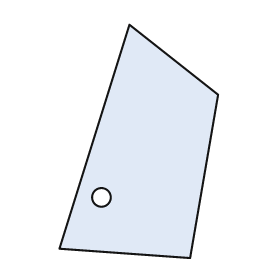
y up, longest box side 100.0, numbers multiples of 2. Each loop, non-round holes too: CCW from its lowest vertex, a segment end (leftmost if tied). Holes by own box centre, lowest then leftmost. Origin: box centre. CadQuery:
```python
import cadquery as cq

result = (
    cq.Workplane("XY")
    .moveTo(22.0, -50.0)
    .lineTo(34.0, 20.0)
    .lineTo(-4.0, 50.0)
    .lineTo(-34.0, -46.0)
    .close()
    .moveTo(-16.0, -24.0)
    .circle(4.0)
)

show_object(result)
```